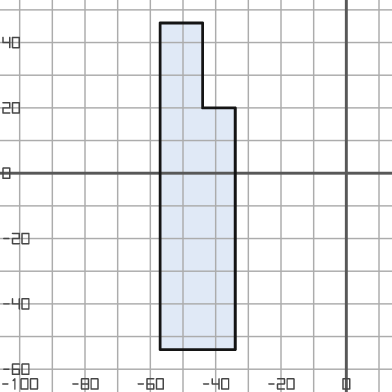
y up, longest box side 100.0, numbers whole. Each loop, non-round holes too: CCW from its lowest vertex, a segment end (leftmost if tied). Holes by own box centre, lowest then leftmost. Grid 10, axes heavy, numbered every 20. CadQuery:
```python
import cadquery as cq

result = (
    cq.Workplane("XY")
    .moveTo(-57.0, -54.0)
    .lineTo(-34.0, -54.0)
    .lineTo(-34.0, 20.0)
    .lineTo(-44.0, 20.0)
    .lineTo(-44.0, 46.0)
    .lineTo(-57.0, 46.0)
    .close()
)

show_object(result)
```